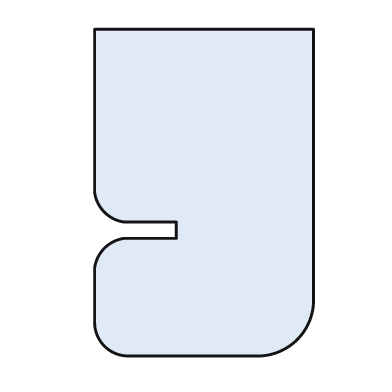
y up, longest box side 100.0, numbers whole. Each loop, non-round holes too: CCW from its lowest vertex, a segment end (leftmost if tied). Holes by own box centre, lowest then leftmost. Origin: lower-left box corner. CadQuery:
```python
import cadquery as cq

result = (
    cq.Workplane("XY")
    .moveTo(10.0, 0.0)
    .lineTo(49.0, 0.0)
    .threePointArc((62.0, 5.0), (67.0, 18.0))
    .lineTo(67.0, 100.0)
    .lineTo(0.0, 100.0)
    .lineTo(0.0, 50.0)
    .threePointArc((3.0, 44.0), (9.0, 41.0))
    .lineTo(25.0, 41.0)
    .lineTo(25.0, 36.0)
    .lineTo(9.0, 36.0)
    .threePointArc((3.0, 33.0), (0.0, 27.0))
    .lineTo(0.0, 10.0)
    .threePointArc((3.0, 3.0), (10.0, 0.0))
    .close()
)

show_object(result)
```